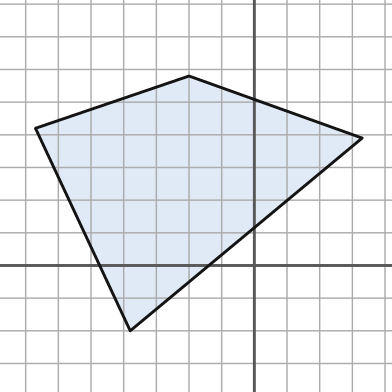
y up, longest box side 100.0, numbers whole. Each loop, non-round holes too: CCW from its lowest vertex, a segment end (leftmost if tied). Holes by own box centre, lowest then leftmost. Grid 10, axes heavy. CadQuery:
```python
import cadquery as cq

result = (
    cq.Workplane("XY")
    .moveTo(-38.0, -20.0)
    .lineTo(33.0, 39.0)
    .lineTo(-20.0, 58.0)
    .lineTo(-67.0, 42.0)
    .close()
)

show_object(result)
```